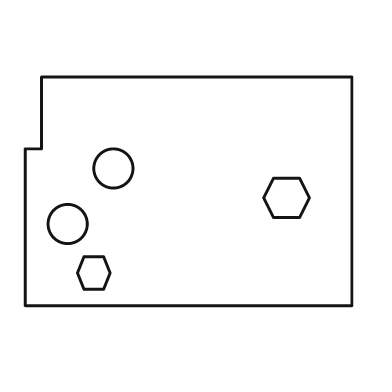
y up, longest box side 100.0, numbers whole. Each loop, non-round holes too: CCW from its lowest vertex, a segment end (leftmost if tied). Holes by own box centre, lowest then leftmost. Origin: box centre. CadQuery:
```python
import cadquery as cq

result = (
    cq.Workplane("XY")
    .moveTo(-50.0, -35.0)
    .lineTo(50.0, -35.0)
    .lineTo(50.0, 35.0)
    .lineTo(-45.0, 35.0)
    .lineTo(-45.0, 13.0)
    .lineTo(-50.0, 13.0)
    .close()
    .moveTo(-32.0, -30.0)
    .lineTo(-26.0, -30.0)
    .lineTo(-24.0, -25.0)
    .lineTo(-26.0, -20.0)
    .lineTo(-32.0, -20.0)
    .lineTo(-34.0, -25.0)
    .close()
    .moveTo(-37.0, -10.0)
    .circle(6.0)
    .moveTo(26.0, -8.0)
    .lineTo(34.0, -8.0)
    .lineTo(37.0, -2.0)
    .lineTo(34.0, 4.0)
    .lineTo(26.0, 4.0)
    .lineTo(23.0, -2.0)
    .close()
    .moveTo(-23.0, 7.0)
    .circle(6.0)
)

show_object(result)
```